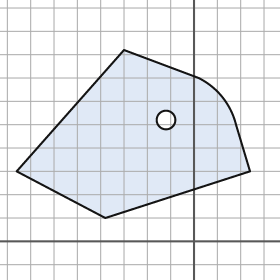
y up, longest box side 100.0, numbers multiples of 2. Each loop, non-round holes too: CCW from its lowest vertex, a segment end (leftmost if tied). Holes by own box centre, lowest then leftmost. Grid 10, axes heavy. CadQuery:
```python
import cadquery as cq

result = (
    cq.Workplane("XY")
    .moveTo(-38.0, 10.0)
    .lineTo(24.0, 30.0)
    .lineTo(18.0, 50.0)
    .threePointArc((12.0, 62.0), (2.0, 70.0))
    .lineTo(-30.0, 82.0)
    .lineTo(-76.0, 30.0)
    .close()
    .moveTo(-12.0, 52.0)
    .circle(4.0)
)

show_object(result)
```